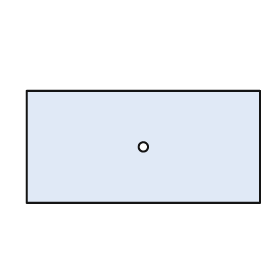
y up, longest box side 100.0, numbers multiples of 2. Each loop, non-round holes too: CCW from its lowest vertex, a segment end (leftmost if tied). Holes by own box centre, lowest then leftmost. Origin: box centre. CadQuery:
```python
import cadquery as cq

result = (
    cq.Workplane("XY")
    .moveTo(-50.0, -24.0)
    .lineTo(50.0, -24.0)
    .lineTo(50.0, 24.0)
    .lineTo(-50.0, 24.0)
    .close()
    .moveTo(0.0, 0.0)
    .circle(2.0)
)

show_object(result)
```